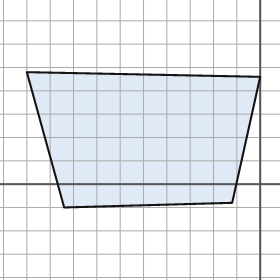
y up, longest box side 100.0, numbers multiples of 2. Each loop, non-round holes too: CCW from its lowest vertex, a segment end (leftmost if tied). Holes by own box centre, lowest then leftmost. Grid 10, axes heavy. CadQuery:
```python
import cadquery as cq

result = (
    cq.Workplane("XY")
    .moveTo(-84.0, -10.0)
    .lineTo(-12.0, -8.0)
    .lineTo(0.0, 46.0)
    .lineTo(-100.0, 48.0)
    .close()
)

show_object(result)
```